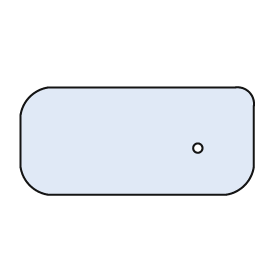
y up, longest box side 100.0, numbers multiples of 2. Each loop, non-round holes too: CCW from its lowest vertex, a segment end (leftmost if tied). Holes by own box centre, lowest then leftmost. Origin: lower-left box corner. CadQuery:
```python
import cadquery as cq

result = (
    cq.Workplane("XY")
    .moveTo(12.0, 0.0)
    .lineTo(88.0, 0.0)
    .threePointArc((96.0, 4.0), (100.0, 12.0))
    .lineTo(100.0, 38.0)
    .threePointArc((98.0, 44.0), (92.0, 46.0))
    .lineTo(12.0, 46.0)
    .threePointArc((4.0, 42.0), (0.0, 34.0))
    .lineTo(0.0, 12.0)
    .threePointArc((4.0, 4.0), (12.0, 0.0))
    .close()
    .moveTo(76.0, 20.0)
    .circle(2.0)
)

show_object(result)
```